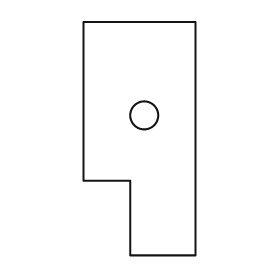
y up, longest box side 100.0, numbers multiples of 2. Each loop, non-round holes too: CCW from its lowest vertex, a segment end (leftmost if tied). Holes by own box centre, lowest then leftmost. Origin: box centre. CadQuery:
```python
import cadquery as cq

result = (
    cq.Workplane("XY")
    .moveTo(-4.0, -50.0)
    .lineTo(24.0, -50.0)
    .lineTo(24.0, 50.0)
    .lineTo(-24.0, 50.0)
    .lineTo(-24.0, -18.0)
    .lineTo(-4.0, -18.0)
    .close()
    .moveTo(2.0, 10.0)
    .circle(6.0)
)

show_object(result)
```